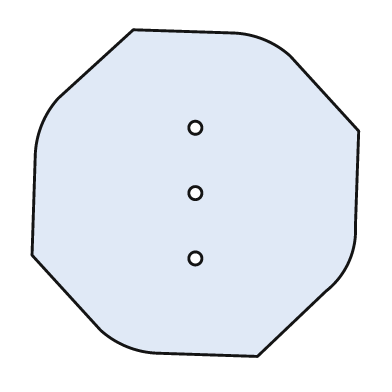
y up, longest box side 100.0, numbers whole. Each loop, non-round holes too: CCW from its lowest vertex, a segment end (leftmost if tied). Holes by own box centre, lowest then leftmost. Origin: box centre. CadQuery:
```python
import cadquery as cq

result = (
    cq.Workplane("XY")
    .moveTo(19.0, -50.0)
    .lineTo(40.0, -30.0)
    .threePointArc((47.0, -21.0), (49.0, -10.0))
    .lineTo(50.0, 19.0)
    .lineTo(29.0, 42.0)
    .threePointArc((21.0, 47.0), (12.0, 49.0))
    .lineTo(-19.0, 50.0)
    .lineTo(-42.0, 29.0)
    .threePointArc((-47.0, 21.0), (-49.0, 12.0))
    .lineTo(-50.0, -19.0)
    .lineTo(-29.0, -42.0)
    .threePointArc((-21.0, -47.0), (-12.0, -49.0))
    .close()
    .moveTo(0.0, -20.0)
    .circle(2.0)
    .moveTo(0.0, 0.0)
    .circle(2.0)
    .moveTo(0.0, 20.0)
    .circle(2.0)
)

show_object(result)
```